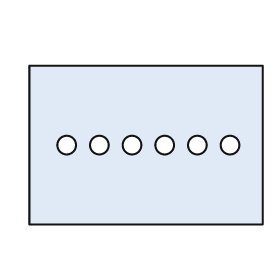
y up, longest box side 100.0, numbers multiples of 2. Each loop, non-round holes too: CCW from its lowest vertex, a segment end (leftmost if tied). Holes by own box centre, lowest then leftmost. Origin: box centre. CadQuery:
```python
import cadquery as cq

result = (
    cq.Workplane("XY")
    .moveTo(-50.0, -34.0)
    .lineTo(50.0, -34.0)
    .lineTo(50.0, 34.0)
    .lineTo(-50.0, 34.0)
    .close()
    .moveTo(-34.0, 0.0)
    .circle(4.0)
    .moveTo(-20.0, 0.0)
    .circle(4.0)
    .moveTo(-6.0, 0.0)
    .circle(4.0)
    .moveTo(8.0, 0.0)
    .circle(4.0)
    .moveTo(22.0, 0.0)
    .circle(4.0)
    .moveTo(36.0, 0.0)
    .circle(4.0)
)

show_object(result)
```